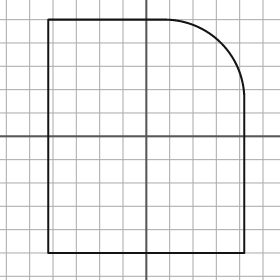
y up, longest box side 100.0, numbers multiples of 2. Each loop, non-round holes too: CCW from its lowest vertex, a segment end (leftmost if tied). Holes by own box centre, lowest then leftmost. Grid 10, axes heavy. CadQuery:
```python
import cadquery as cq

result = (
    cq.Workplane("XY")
    .moveTo(-42.0, -50.0)
    .lineTo(42.0, -50.0)
    .lineTo(42.0, 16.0)
    .threePointArc((32.0, 40.0), (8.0, 50.0))
    .lineTo(-42.0, 50.0)
    .close()
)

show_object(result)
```